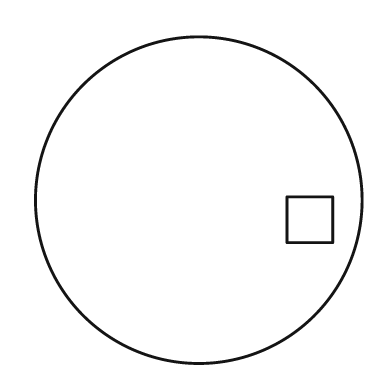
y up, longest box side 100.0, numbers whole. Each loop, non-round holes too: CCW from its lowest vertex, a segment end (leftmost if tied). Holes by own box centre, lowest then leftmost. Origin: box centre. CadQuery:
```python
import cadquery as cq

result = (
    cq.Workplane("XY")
    .moveTo(0.0, 0.0)
    .circle(50.0)
    .moveTo(27.0, -13.0)
    .lineTo(41.0, -13.0)
    .lineTo(41.0, 1.0)
    .lineTo(27.0, 1.0)
    .close()
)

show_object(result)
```